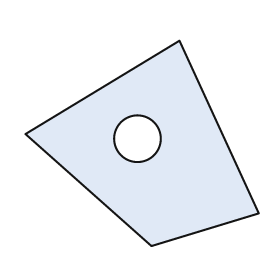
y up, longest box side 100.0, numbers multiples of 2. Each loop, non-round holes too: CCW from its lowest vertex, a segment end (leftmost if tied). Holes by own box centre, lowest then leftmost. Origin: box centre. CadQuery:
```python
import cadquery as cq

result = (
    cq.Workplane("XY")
    .moveTo(4.0, -44.0)
    .lineTo(50.0, -30.0)
    .lineTo(16.0, 44.0)
    .lineTo(-50.0, 4.0)
    .close()
    .moveTo(-2.0, 2.0)
    .circle(10.0)
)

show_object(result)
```